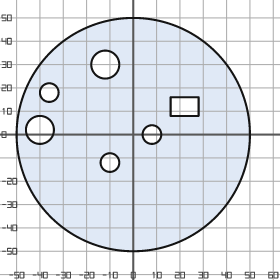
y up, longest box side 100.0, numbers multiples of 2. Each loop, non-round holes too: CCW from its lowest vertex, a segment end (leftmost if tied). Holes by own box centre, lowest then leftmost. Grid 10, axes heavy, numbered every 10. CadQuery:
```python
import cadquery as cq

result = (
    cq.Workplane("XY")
    .moveTo(0.0, 0.0)
    .circle(50.0)
    .moveTo(-10.0, -12.0)
    .circle(4.0)
    .moveTo(8.0, 0.0)
    .circle(4.0)
    .moveTo(-40.0, 2.0)
    .circle(6.0)
    .moveTo(16.0, 8.0)
    .lineTo(28.0, 8.0)
    .lineTo(28.0, 16.0)
    .lineTo(16.0, 16.0)
    .close()
    .moveTo(-36.0, 18.0)
    .circle(4.0)
    .moveTo(-12.0, 30.0)
    .circle(6.0)
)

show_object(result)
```